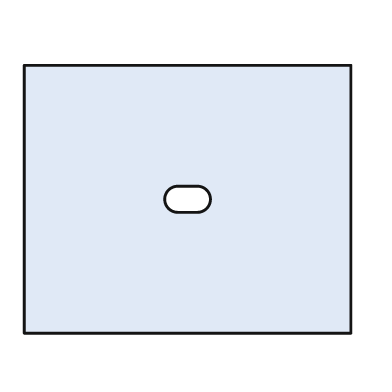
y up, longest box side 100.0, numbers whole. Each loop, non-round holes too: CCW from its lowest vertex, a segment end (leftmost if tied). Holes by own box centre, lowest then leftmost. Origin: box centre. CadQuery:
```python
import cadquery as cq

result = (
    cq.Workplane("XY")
    .moveTo(-50.0, -41.0)
    .lineTo(50.0, -41.0)
    .lineTo(50.0, 41.0)
    .lineTo(-50.0, 41.0)
    .close()
    .moveTo(-3.0, -4.0)
    .lineTo(3.0, -4.0)
    .threePointArc((7.0, 0.0), (3.0, 4.0))
    .lineTo(-3.0, 4.0)
    .threePointArc((-7.0, 0.0), (-3.0, -4.0))
    .close()
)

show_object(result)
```